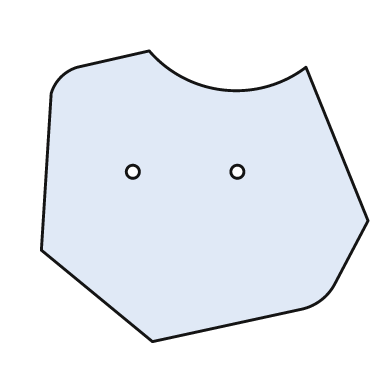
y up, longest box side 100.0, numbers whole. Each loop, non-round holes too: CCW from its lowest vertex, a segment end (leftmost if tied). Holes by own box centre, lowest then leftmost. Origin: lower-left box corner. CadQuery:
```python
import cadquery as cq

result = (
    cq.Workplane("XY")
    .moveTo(34.0, 0.0)
    .lineTo(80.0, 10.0)
    .threePointArc((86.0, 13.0), (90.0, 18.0))
    .lineTo(100.0, 37.0)
    .lineTo(81.0, 84.0)
    .threePointArc((56.0, 77.0), (33.0, 89.0))
    .lineTo(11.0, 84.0)
    .threePointArc((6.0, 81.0), (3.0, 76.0))
    .lineTo(0.0, 28.0)
    .close()
    .moveTo(28.0, 52.0)
    .circle(2.0)
    .moveTo(60.0, 52.0)
    .circle(2.0)
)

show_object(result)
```